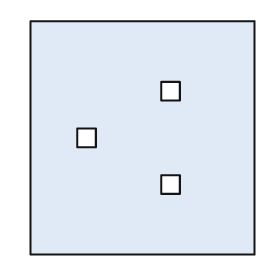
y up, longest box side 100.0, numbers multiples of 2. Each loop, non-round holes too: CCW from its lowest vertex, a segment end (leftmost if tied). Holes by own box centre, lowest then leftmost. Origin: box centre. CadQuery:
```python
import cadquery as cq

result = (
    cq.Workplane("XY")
    .moveTo(-48.0, -50.0)
    .lineTo(48.0, -50.0)
    .lineTo(48.0, 50.0)
    .lineTo(-48.0, 50.0)
    .close()
    .moveTo(8.0, -24.0)
    .lineTo(16.0, -24.0)
    .lineTo(16.0, -16.0)
    .lineTo(8.0, -16.0)
    .close()
    .moveTo(-28.0, -4.0)
    .lineTo(-20.0, -4.0)
    .lineTo(-20.0, 4.0)
    .lineTo(-28.0, 4.0)
    .close()
    .moveTo(8.0, 16.0)
    .lineTo(16.0, 16.0)
    .lineTo(16.0, 24.0)
    .lineTo(8.0, 24.0)
    .close()
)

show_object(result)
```